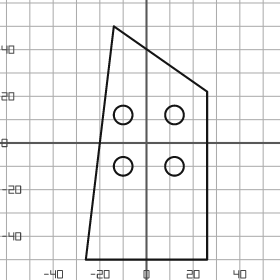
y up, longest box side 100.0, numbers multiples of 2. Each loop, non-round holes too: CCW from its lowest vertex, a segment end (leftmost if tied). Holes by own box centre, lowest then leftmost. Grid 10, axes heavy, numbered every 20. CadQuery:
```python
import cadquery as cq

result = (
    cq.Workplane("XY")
    .moveTo(-26.0, -50.0)
    .lineTo(26.0, -50.0)
    .lineTo(26.0, 22.0)
    .lineTo(-14.0, 50.0)
    .close()
    .moveTo(-10.0, -10.0)
    .circle(4.0)
    .moveTo(12.0, -10.0)
    .circle(4.0)
    .moveTo(-10.0, 12.0)
    .circle(4.0)
    .moveTo(12.0, 12.0)
    .circle(4.0)
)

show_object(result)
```